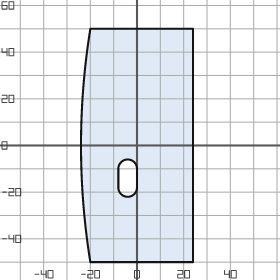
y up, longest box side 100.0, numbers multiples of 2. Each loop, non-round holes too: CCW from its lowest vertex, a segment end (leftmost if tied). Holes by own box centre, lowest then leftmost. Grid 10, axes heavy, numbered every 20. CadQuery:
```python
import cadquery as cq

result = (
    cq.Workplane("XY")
    .moveTo(-20.0, -50.0)
    .lineTo(24.0, -50.0)
    .lineTo(24.0, 50.0)
    .lineTo(-20.0, 50.0)
    .threePointArc((-24.0, 0.0), (-20.0, -50.0))
    .close()
    .moveTo(-8.0, -18.0)
    .threePointArc((-4.0, -22.0), (0.0, -18.0))
    .lineTo(0.0, -10.0)
    .threePointArc((-4.0, -6.0), (-8.0, -10.0))
    .close()
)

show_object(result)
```